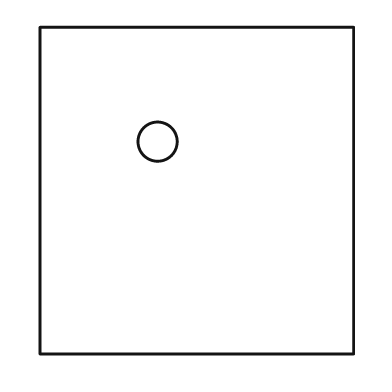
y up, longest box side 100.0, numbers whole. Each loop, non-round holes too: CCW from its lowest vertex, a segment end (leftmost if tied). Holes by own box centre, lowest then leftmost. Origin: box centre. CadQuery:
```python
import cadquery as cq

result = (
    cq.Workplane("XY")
    .moveTo(-48.0, -50.0)
    .lineTo(48.0, -50.0)
    .lineTo(48.0, 50.0)
    .lineTo(-48.0, 50.0)
    .close()
    .moveTo(-12.0, 15.0)
    .circle(6.0)
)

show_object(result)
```